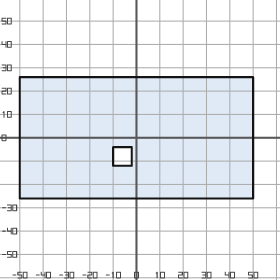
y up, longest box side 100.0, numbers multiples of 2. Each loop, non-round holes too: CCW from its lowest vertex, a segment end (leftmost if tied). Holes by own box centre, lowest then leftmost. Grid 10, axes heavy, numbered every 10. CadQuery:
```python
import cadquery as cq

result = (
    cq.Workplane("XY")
    .moveTo(-50.0, -26.0)
    .lineTo(50.0, -26.0)
    .lineTo(50.0, 26.0)
    .lineTo(-50.0, 26.0)
    .close()
    .moveTo(-10.0, -12.0)
    .lineTo(-2.0, -12.0)
    .lineTo(-2.0, -4.0)
    .lineTo(-10.0, -4.0)
    .close()
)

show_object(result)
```